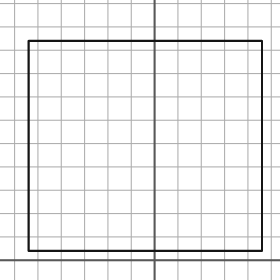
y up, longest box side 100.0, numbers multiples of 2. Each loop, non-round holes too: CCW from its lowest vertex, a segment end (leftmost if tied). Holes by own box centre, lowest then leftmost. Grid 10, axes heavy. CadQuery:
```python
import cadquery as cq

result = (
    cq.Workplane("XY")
    .moveTo(-54.0, 4.0)
    .lineTo(46.0, 4.0)
    .lineTo(46.0, 94.0)
    .lineTo(-54.0, 94.0)
    .close()
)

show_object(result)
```